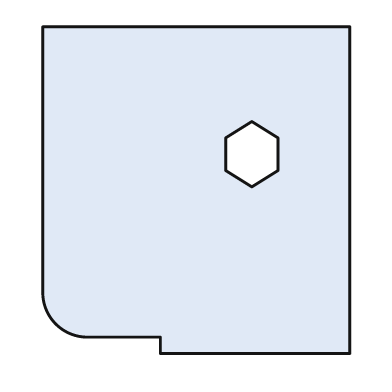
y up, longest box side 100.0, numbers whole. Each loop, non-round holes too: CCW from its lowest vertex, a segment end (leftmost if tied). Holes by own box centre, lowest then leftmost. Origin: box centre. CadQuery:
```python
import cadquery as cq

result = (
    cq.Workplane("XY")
    .moveTo(-11.0, -50.0)
    .lineTo(47.0, -50.0)
    .lineTo(47.0, 50.0)
    .lineTo(-47.0, 50.0)
    .lineTo(-47.0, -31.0)
    .threePointArc((-43.0, -41.0), (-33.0, -45.0))
    .lineTo(-11.0, -45.0)
    .close()
    .moveTo(17.0, 1.0)
    .lineTo(25.0, 6.0)
    .lineTo(25.0, 16.0)
    .lineTo(17.0, 21.0)
    .lineTo(9.0, 16.0)
    .lineTo(9.0, 6.0)
    .close()
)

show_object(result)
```